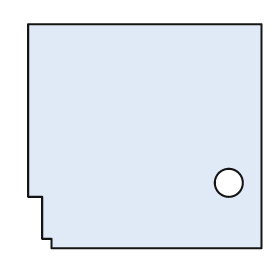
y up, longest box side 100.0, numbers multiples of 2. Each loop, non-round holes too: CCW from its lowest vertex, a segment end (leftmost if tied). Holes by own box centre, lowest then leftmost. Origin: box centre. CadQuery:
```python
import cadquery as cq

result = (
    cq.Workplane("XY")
    .moveTo(-40.0, -48.0)
    .lineTo(50.0, -48.0)
    .lineTo(50.0, 48.0)
    .lineTo(-50.0, 48.0)
    .lineTo(-50.0, -26.0)
    .lineTo(-44.0, -26.0)
    .lineTo(-44.0, -44.0)
    .lineTo(-40.0, -44.0)
    .close()
    .moveTo(36.0, -20.0)
    .circle(6.0)
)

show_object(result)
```